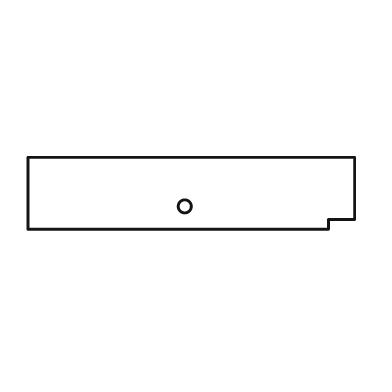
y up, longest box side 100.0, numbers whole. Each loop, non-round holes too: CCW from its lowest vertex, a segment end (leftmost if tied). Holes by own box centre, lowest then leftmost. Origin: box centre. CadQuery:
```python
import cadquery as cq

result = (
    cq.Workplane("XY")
    .moveTo(-50.0, -11.0)
    .lineTo(42.0, -11.0)
    .lineTo(42.0, -8.0)
    .lineTo(50.0, -8.0)
    .lineTo(50.0, 11.0)
    .lineTo(-50.0, 11.0)
    .close()
    .moveTo(-2.0, -4.0)
    .circle(2.0)
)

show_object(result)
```